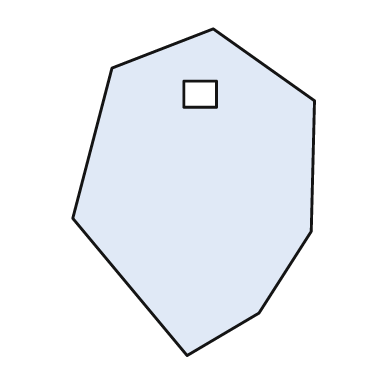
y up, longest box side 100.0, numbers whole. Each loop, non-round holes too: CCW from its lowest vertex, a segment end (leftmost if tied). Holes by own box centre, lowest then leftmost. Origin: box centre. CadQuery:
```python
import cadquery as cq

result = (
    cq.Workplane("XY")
    .moveTo(-2.0, -50.0)
    .lineTo(20.0, -37.0)
    .lineTo(36.0, -12.0)
    .lineTo(37.0, 28.0)
    .lineTo(6.0, 50.0)
    .lineTo(-25.0, 38.0)
    .lineTo(-37.0, -8.0)
    .close()
    .moveTo(-3.0, 26.0)
    .lineTo(7.0, 26.0)
    .lineTo(7.0, 34.0)
    .lineTo(-3.0, 34.0)
    .close()
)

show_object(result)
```